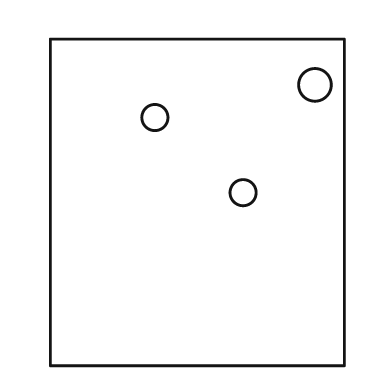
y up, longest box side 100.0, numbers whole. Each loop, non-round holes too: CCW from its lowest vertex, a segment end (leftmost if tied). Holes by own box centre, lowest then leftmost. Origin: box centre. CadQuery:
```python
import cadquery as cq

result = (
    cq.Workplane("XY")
    .moveTo(-45.0, -50.0)
    .lineTo(45.0, -50.0)
    .lineTo(45.0, 50.0)
    .lineTo(-45.0, 50.0)
    .close()
    .moveTo(14.0, 3.0)
    .circle(4.0)
    .moveTo(-13.0, 26.0)
    .circle(4.0)
    .moveTo(36.0, 36.0)
    .circle(5.0)
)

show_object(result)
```